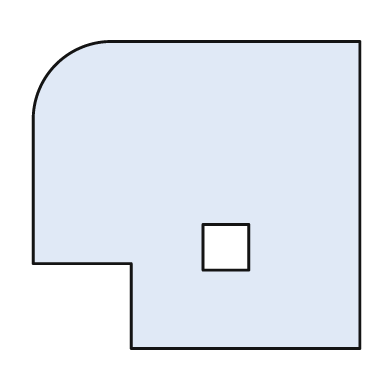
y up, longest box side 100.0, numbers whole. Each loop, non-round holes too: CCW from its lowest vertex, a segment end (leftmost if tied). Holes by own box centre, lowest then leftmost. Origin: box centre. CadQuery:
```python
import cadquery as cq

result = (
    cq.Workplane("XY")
    .moveTo(-20.0, -47.0)
    .lineTo(50.0, -47.0)
    .lineTo(50.0, 47.0)
    .lineTo(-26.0, 47.0)
    .threePointArc((-43.0, 40.0), (-50.0, 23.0))
    .lineTo(-50.0, -21.0)
    .lineTo(-20.0, -21.0)
    .close()
    .moveTo(2.0, -23.0)
    .lineTo(16.0, -23.0)
    .lineTo(16.0, -9.0)
    .lineTo(2.0, -9.0)
    .close()
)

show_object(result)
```